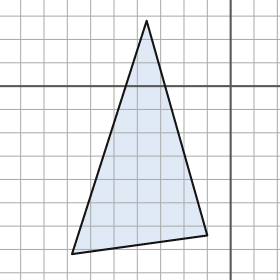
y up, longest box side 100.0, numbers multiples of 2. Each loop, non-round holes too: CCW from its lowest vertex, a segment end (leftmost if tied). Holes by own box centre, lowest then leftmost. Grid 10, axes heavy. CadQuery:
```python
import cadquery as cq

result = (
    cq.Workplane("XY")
    .moveTo(-68.0, -72.0)
    .lineTo(-10.0, -64.0)
    .lineTo(-36.0, 28.0)
    .close()
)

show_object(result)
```